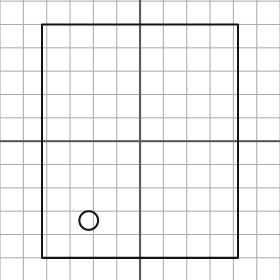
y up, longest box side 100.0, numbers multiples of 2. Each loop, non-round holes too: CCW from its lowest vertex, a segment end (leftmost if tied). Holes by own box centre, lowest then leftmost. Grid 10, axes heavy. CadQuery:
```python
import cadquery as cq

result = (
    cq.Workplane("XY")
    .moveTo(-42.0, -50.0)
    .lineTo(42.0, -50.0)
    .lineTo(42.0, 50.0)
    .lineTo(-42.0, 50.0)
    .close()
    .moveTo(-22.0, -34.0)
    .circle(4.0)
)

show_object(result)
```